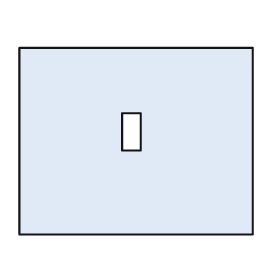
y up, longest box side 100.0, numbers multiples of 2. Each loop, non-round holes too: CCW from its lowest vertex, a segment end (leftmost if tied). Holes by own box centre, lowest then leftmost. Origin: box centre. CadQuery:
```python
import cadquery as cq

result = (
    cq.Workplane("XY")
    .moveTo(-50.0, -40.0)
    .lineTo(50.0, -40.0)
    .lineTo(50.0, 40.0)
    .lineTo(-50.0, 40.0)
    .close()
    .moveTo(-6.0, -4.0)
    .lineTo(2.0, -4.0)
    .lineTo(2.0, 12.0)
    .lineTo(-6.0, 12.0)
    .close()
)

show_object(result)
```